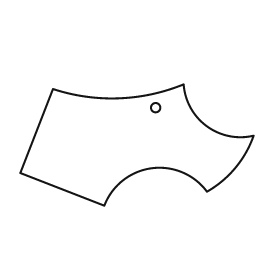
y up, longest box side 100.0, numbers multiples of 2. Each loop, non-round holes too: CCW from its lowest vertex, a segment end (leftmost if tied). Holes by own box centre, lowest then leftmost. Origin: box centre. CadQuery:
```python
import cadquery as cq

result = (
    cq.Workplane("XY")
    .moveTo(-14.0, -26.0)
    .threePointArc((6.0, -10.0), (30.0, -20.0))
    .threePointArc((42.0, -10.0), (50.0, 4.0))
    .threePointArc((30.0, 8.0), (20.0, 26.0))
    .threePointArc((-8.0, 20.0), (-36.0, 24.0))
    .lineTo(-50.0, -12.0)
    .close()
    .moveTo(8.0, 16.0)
    .circle(2.0)
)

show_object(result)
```